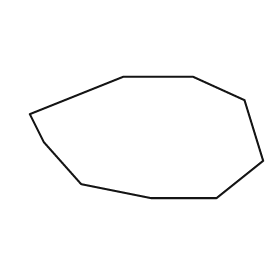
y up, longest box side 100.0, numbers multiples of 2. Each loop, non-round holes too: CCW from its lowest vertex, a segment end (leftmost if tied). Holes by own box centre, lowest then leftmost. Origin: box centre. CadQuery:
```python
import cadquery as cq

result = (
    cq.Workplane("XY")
    .moveTo(2.0, -26.0)
    .lineTo(30.0, -26.0)
    .lineTo(50.0, -10.0)
    .lineTo(42.0, 16.0)
    .lineTo(20.0, 26.0)
    .lineTo(-10.0, 26.0)
    .lineTo(-50.0, 10.0)
    .lineTo(-44.0, -2.0)
    .lineTo(-28.0, -20.0)
    .close()
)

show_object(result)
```